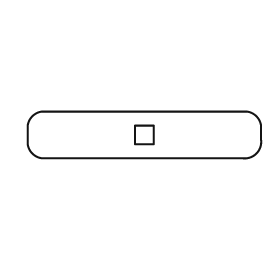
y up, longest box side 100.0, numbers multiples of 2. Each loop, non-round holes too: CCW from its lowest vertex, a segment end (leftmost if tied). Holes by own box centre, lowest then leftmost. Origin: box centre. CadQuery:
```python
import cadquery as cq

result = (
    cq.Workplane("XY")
    .moveTo(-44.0, -10.0)
    .lineTo(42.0, -10.0)
    .threePointArc((48.0, -8.0), (50.0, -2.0))
    .lineTo(50.0, 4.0)
    .threePointArc((48.0, 8.0), (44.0, 10.0))
    .lineTo(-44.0, 10.0)
    .threePointArc((-48.0, 8.0), (-50.0, 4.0))
    .lineTo(-50.0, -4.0)
    .threePointArc((-48.0, -8.0), (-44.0, -10.0))
    .close()
    .moveTo(-4.0, -4.0)
    .lineTo(4.0, -4.0)
    .lineTo(4.0, 4.0)
    .lineTo(-4.0, 4.0)
    .close()
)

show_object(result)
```